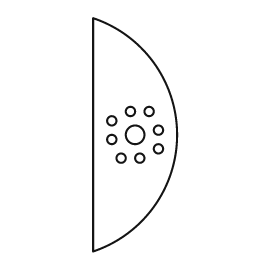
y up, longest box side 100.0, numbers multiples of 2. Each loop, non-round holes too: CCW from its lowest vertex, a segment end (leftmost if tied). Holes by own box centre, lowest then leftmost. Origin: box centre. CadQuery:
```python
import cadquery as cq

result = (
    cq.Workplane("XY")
    .moveTo(-18.0, -50.0)
    .threePointArc((18.0, 0.0), (-18.0, 50.0))
    .close()
    .moveTo(-6.0, -10.0)
    .circle(2.0)
    .moveTo(2.0, -10.0)
    .circle(2.0)
    .moveTo(10.0, -6.0)
    .circle(2.0)
    .moveTo(-10.0, -2.0)
    .circle(2.0)
    .moveTo(0.0, 0.0)
    .circle(4.0)
    .moveTo(10.0, 2.0)
    .circle(2.0)
    .moveTo(-10.0, 6.0)
    .circle(2.0)
    .moveTo(-2.0, 10.0)
    .circle(2.0)
    .moveTo(6.0, 10.0)
    .circle(2.0)
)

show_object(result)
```